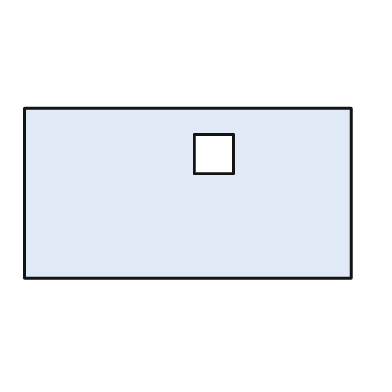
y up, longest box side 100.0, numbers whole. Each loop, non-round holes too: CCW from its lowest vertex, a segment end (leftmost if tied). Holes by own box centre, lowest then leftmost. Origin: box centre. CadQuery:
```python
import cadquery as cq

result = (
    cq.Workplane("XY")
    .moveTo(-50.0, -26.0)
    .lineTo(50.0, -26.0)
    .lineTo(50.0, 26.0)
    .lineTo(-50.0, 26.0)
    .close()
    .moveTo(2.0, 6.0)
    .lineTo(14.0, 6.0)
    .lineTo(14.0, 18.0)
    .lineTo(2.0, 18.0)
    .close()
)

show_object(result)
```